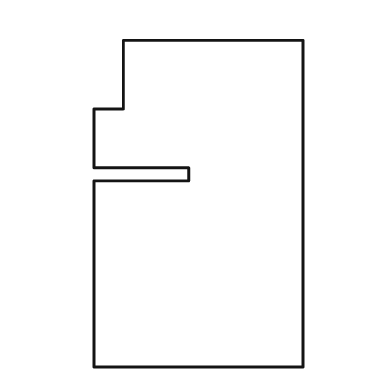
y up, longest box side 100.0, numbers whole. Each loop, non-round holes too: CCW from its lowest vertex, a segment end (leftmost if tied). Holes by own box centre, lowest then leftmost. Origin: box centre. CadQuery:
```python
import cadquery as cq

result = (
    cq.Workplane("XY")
    .moveTo(-32.0, -50.0)
    .lineTo(32.0, -50.0)
    .lineTo(32.0, 50.0)
    .lineTo(-23.0, 50.0)
    .lineTo(-23.0, 29.0)
    .lineTo(-32.0, 29.0)
    .lineTo(-32.0, 11.0)
    .lineTo(-3.0, 11.0)
    .lineTo(-3.0, 7.0)
    .lineTo(-32.0, 7.0)
    .close()
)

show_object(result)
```